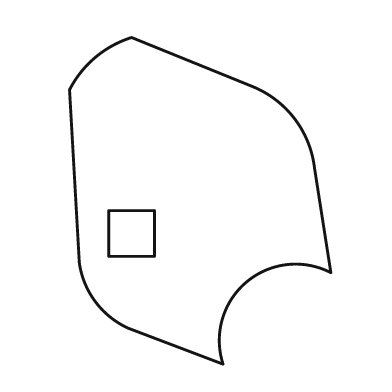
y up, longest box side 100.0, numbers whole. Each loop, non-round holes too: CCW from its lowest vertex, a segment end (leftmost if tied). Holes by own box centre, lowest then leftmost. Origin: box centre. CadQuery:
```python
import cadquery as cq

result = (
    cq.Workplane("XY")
    .moveTo(7.0, -50.0)
    .threePointArc((14.0, -25.0), (40.0, -22.0))
    .lineTo(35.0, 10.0)
    .threePointArc((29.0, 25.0), (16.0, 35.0))
    .lineTo(-21.0, 50.0)
    .threePointArc((-32.0, 44.0), (-40.0, 34.0))
    .lineTo(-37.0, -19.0)
    .threePointArc((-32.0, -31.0), (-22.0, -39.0))
    .close()
    .moveTo(-28.0, -17.0)
    .lineTo(-14.0, -17.0)
    .lineTo(-14.0, -3.0)
    .lineTo(-28.0, -3.0)
    .close()
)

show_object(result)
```